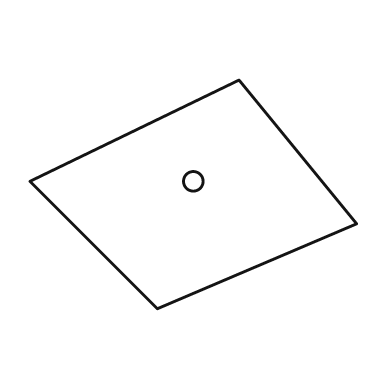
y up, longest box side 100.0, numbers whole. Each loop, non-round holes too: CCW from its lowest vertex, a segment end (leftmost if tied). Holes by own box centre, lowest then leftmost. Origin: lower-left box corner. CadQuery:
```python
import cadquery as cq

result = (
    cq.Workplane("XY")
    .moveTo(39.0, 0.0)
    .lineTo(100.0, 26.0)
    .lineTo(64.0, 70.0)
    .lineTo(0.0, 39.0)
    .close()
    .moveTo(50.0, 39.0)
    .circle(3.0)
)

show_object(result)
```